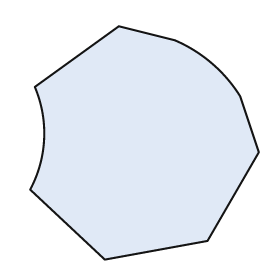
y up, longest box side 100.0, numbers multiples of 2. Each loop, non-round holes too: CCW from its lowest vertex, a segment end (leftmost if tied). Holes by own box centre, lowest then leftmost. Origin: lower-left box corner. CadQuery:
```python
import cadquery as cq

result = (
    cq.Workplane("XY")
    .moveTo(32.0, 0.0)
    .lineTo(76.0, 8.0)
    .lineTo(98.0, 46.0)
    .lineTo(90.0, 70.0)
    .threePointArc((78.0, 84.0), (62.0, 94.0))
    .lineTo(38.0, 100.0)
    .lineTo(2.0, 74.0)
    .threePointArc((6.0, 52.0), (0.0, 30.0))
    .close()
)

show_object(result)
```